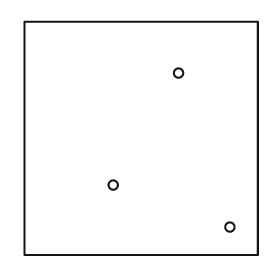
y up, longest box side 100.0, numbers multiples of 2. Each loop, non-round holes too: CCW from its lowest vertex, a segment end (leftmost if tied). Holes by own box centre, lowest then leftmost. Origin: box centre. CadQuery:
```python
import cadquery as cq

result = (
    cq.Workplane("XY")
    .moveTo(-50.0, -50.0)
    .lineTo(50.0, -50.0)
    .lineTo(50.0, 50.0)
    .lineTo(-50.0, 50.0)
    .close()
    .moveTo(38.0, -38.0)
    .circle(2.0)
    .moveTo(-12.0, -20.0)
    .circle(2.0)
    .moveTo(16.0, 28.0)
    .circle(2.0)
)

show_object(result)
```